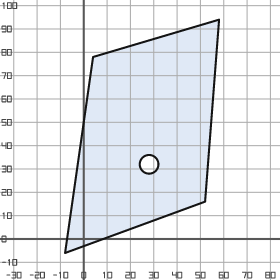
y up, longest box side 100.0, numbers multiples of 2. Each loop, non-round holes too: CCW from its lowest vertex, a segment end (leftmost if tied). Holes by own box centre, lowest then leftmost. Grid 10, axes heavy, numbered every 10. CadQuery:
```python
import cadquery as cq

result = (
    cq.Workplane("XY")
    .moveTo(-8.0, -6.0)
    .lineTo(52.0, 16.0)
    .lineTo(58.0, 94.0)
    .lineTo(4.0, 78.0)
    .close()
    .moveTo(28.0, 32.0)
    .circle(4.0)
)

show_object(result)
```